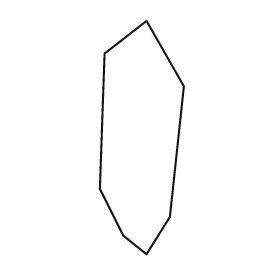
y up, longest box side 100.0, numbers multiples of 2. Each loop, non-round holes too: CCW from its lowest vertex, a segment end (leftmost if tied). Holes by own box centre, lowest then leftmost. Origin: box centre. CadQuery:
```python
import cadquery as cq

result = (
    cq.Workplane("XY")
    .moveTo(2.0, -50.0)
    .lineTo(12.0, -34.0)
    .lineTo(18.0, 22.0)
    .lineTo(2.0, 50.0)
    .lineTo(-16.0, 36.0)
    .lineTo(-18.0, -22.0)
    .lineTo(-8.0, -42.0)
    .close()
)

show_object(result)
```